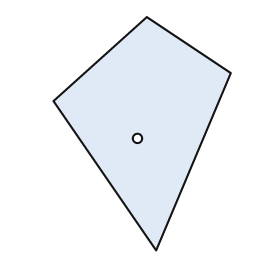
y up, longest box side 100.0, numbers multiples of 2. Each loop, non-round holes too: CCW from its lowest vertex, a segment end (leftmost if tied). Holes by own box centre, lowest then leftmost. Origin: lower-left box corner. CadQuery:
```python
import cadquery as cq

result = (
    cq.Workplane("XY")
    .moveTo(44.0, 0.0)
    .lineTo(76.0, 76.0)
    .lineTo(40.0, 100.0)
    .lineTo(0.0, 64.0)
    .close()
    .moveTo(36.0, 48.0)
    .circle(2.0)
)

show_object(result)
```